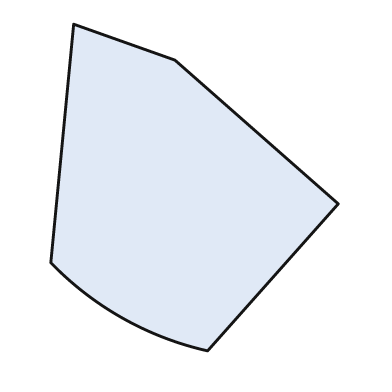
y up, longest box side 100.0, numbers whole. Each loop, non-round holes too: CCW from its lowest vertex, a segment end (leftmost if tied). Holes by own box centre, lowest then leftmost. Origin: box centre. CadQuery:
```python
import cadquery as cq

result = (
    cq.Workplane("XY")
    .moveTo(4.0, -50.0)
    .lineTo(44.0, -5.0)
    .lineTo(-6.0, 39.0)
    .lineTo(-37.0, 50.0)
    .lineTo(-44.0, -23.0)
    .threePointArc((-22.0, -40.0), (4.0, -50.0))
    .close()
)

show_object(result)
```